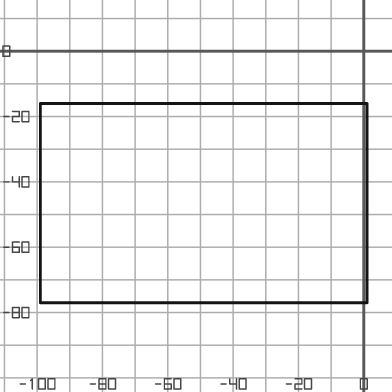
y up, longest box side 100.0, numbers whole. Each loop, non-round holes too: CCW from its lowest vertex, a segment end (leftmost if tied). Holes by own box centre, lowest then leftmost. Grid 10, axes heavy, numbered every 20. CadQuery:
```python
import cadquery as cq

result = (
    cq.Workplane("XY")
    .moveTo(-99.0, -77.0)
    .lineTo(1.0, -77.0)
    .lineTo(1.0, -16.0)
    .lineTo(-99.0, -16.0)
    .close()
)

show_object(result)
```